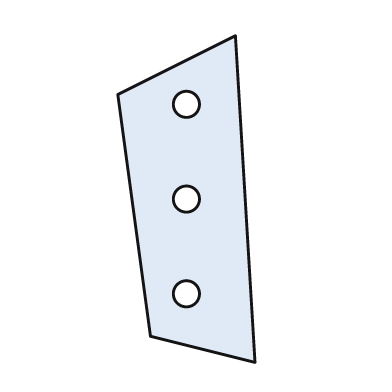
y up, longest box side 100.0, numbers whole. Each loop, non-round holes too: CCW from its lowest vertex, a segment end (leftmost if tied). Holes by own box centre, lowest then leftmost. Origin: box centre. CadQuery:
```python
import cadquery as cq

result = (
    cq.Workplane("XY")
    .moveTo(21.0, -50.0)
    .lineTo(15.0, 50.0)
    .lineTo(-21.0, 32.0)
    .lineTo(-11.0, -42.0)
    .close()
    .moveTo(0.0, -29.0)
    .circle(4.0)
    .moveTo(0.0, 0.0)
    .circle(4.0)
    .moveTo(0.0, 29.0)
    .circle(4.0)
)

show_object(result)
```